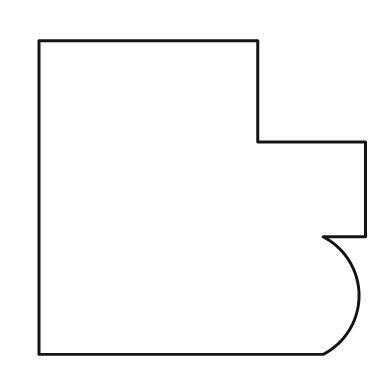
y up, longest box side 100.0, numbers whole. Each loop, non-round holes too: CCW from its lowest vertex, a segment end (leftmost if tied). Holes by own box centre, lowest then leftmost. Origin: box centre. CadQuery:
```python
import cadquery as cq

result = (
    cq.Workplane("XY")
    .moveTo(-50.0, -48.0)
    .lineTo(37.0, -48.0)
    .threePointArc((48.0, -30.0), (37.0, -12.0))
    .lineTo(50.0, -12.0)
    .lineTo(50.0, 17.0)
    .lineTo(17.0, 17.0)
    .lineTo(17.0, 48.0)
    .lineTo(-50.0, 48.0)
    .close()
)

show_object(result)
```